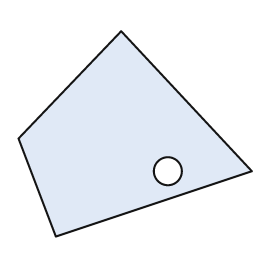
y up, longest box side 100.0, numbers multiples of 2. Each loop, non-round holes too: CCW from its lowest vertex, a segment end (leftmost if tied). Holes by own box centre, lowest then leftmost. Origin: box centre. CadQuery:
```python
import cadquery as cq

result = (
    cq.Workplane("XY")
    .moveTo(-34.0, -44.0)
    .lineTo(50.0, -16.0)
    .lineTo(-6.0, 44.0)
    .lineTo(-50.0, -2.0)
    .close()
    .moveTo(14.0, -16.0)
    .circle(6.0)
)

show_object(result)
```